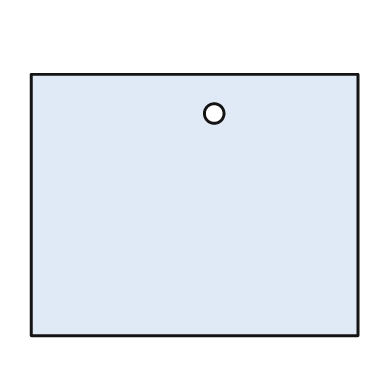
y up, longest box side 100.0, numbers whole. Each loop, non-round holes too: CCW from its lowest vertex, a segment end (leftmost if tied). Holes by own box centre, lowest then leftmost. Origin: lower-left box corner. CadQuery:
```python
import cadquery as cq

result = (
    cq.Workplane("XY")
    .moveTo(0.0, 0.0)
    .lineTo(100.0, 0.0)
    .lineTo(100.0, 80.0)
    .lineTo(0.0, 80.0)
    .close()
    .moveTo(56.0, 68.0)
    .circle(3.0)
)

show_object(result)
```